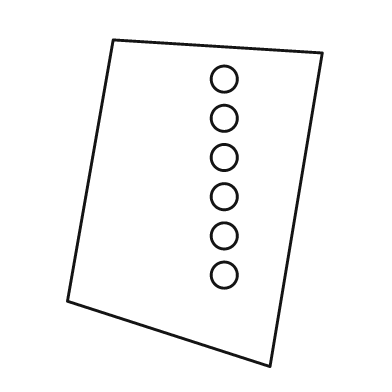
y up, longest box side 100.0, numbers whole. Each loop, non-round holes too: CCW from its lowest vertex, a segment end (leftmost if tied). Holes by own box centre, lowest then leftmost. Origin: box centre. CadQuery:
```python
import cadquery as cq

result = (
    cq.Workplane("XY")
    .moveTo(23.0, -50.0)
    .lineTo(39.0, 46.0)
    .lineTo(-25.0, 50.0)
    .lineTo(-39.0, -30.0)
    .close()
    .moveTo(9.0, -22.0)
    .circle(4.0)
    .moveTo(9.0, -10.0)
    .circle(4.0)
    .moveTo(9.0, 2.0)
    .circle(4.0)
    .moveTo(9.0, 14.0)
    .circle(4.0)
    .moveTo(9.0, 26.0)
    .circle(4.0)
    .moveTo(9.0, 38.0)
    .circle(4.0)
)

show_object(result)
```